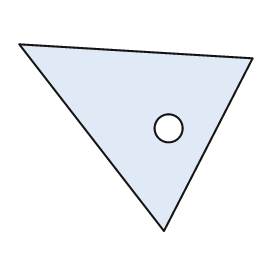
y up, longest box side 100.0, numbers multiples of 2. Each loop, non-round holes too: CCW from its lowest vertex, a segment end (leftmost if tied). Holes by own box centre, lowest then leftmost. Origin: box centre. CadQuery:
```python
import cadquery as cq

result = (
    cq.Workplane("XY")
    .moveTo(12.0, -40.0)
    .lineTo(50.0, 34.0)
    .lineTo(-50.0, 40.0)
    .close()
    .moveTo(14.0, 4.0)
    .circle(6.0)
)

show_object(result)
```